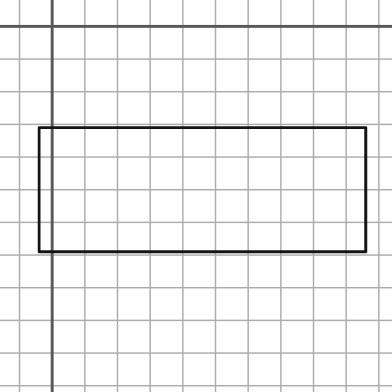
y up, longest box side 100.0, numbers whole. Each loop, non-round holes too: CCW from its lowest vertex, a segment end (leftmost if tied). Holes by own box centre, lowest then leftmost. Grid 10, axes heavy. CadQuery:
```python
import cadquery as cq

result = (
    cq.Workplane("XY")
    .moveTo(-4.0, -69.0)
    .lineTo(96.0, -69.0)
    .lineTo(96.0, -31.0)
    .lineTo(-4.0, -31.0)
    .close()
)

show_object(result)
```